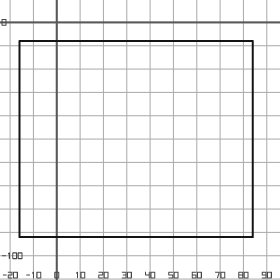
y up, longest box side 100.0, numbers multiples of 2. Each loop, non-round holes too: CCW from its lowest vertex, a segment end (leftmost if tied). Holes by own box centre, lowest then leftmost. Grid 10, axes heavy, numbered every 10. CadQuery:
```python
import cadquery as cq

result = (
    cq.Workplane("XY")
    .moveTo(-16.0, -92.0)
    .lineTo(84.0, -92.0)
    .lineTo(84.0, -8.0)
    .lineTo(-16.0, -8.0)
    .close()
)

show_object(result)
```